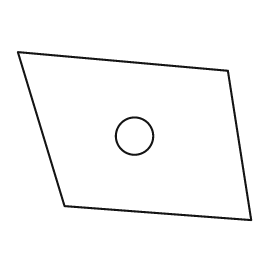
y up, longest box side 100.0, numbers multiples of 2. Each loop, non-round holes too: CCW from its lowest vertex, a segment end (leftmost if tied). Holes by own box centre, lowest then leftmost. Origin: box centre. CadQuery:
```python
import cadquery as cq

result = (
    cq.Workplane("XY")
    .moveTo(50.0, -36.0)
    .lineTo(40.0, 28.0)
    .lineTo(-50.0, 36.0)
    .lineTo(-30.0, -30.0)
    .close()
    .moveTo(0.0, 0.0)
    .circle(8.0)
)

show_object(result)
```